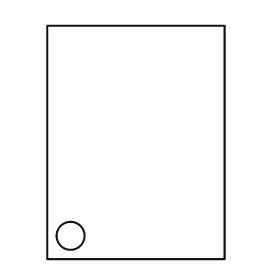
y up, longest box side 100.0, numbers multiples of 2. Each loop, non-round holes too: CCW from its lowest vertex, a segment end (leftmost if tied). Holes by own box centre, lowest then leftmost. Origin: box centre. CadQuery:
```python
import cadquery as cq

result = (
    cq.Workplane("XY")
    .moveTo(-38.0, -50.0)
    .lineTo(38.0, -50.0)
    .lineTo(38.0, 50.0)
    .lineTo(-38.0, 50.0)
    .close()
    .moveTo(-28.0, -40.0)
    .circle(6.0)
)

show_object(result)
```